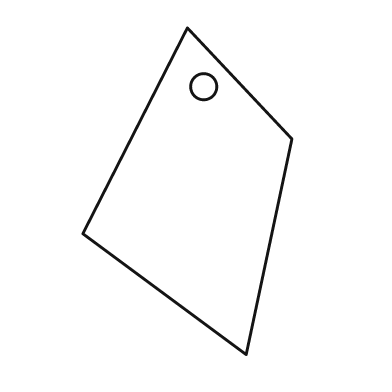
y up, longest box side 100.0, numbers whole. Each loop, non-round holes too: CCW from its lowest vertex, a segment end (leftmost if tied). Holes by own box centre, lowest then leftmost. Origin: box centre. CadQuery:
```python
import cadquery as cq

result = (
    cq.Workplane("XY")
    .moveTo(18.0, -50.0)
    .lineTo(32.0, 16.0)
    .lineTo(0.0, 50.0)
    .lineTo(-32.0, -13.0)
    .close()
    .moveTo(5.0, 32.0)
    .circle(4.0)
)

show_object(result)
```